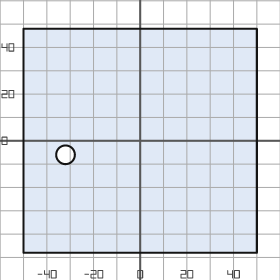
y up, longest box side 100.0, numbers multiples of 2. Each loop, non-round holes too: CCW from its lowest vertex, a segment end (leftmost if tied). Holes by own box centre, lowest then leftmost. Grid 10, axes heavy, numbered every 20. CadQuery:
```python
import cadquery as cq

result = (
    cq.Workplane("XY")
    .moveTo(-50.0, -48.0)
    .lineTo(50.0, -48.0)
    .lineTo(50.0, 48.0)
    .lineTo(-50.0, 48.0)
    .close()
    .moveTo(-32.0, -6.0)
    .circle(4.0)
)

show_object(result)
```